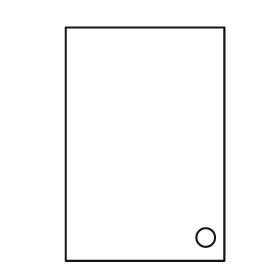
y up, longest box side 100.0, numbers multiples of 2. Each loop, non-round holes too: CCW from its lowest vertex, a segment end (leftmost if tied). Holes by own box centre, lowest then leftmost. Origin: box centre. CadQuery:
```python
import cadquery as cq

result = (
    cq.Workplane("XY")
    .moveTo(-34.0, -50.0)
    .lineTo(34.0, -50.0)
    .lineTo(34.0, 50.0)
    .lineTo(-34.0, 50.0)
    .close()
    .moveTo(26.0, -40.0)
    .circle(4.0)
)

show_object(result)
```